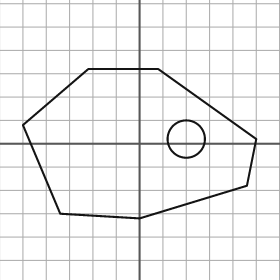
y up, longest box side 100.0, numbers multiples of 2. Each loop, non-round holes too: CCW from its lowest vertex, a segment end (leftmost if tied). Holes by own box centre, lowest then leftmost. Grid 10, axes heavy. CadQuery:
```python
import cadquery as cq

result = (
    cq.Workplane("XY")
    .moveTo(0.0, -32.0)
    .lineTo(46.0, -18.0)
    .lineTo(50.0, 2.0)
    .lineTo(8.0, 32.0)
    .lineTo(-22.0, 32.0)
    .lineTo(-50.0, 8.0)
    .lineTo(-34.0, -30.0)
    .close()
    .moveTo(20.0, 2.0)
    .circle(8.0)
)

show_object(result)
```